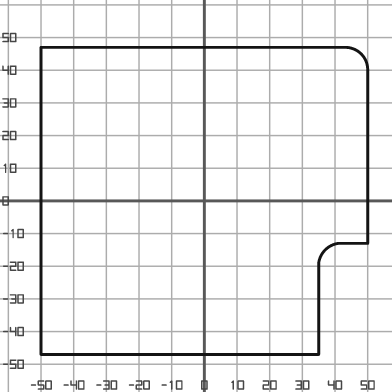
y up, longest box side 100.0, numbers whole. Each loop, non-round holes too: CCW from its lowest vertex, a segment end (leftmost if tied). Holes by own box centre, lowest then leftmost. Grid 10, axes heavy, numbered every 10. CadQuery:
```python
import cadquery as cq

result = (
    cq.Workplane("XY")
    .moveTo(-50.0, -47.0)
    .lineTo(35.0, -47.0)
    .lineTo(35.0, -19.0)
    .threePointArc((37.0, -15.0), (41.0, -13.0))
    .lineTo(50.0, -13.0)
    .lineTo(50.0, 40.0)
    .threePointArc((48.0, 45.0), (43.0, 47.0))
    .lineTo(-50.0, 47.0)
    .close()
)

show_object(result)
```